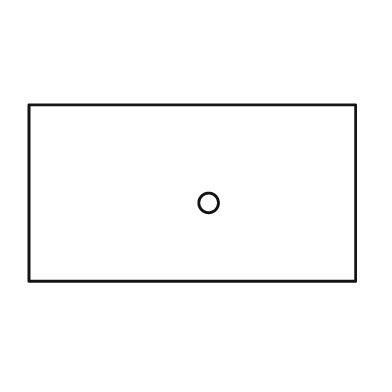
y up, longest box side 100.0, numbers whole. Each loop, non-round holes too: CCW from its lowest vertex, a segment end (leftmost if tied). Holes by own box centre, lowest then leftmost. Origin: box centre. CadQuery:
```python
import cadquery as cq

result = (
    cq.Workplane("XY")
    .moveTo(-50.0, -27.0)
    .lineTo(50.0, -27.0)
    .lineTo(50.0, 27.0)
    .lineTo(-50.0, 27.0)
    .close()
    .moveTo(5.0, -3.0)
    .circle(3.0)
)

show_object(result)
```